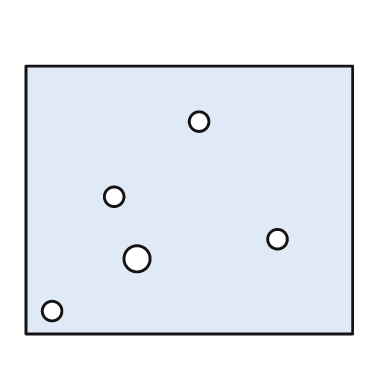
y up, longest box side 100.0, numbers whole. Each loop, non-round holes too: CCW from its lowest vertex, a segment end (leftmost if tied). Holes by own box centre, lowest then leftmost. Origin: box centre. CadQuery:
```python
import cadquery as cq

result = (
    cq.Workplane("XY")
    .moveTo(-50.0, -41.0)
    .lineTo(50.0, -41.0)
    .lineTo(50.0, 41.0)
    .lineTo(-50.0, 41.0)
    .close()
    .moveTo(-42.0, -34.0)
    .circle(3.0)
    .moveTo(-16.0, -18.0)
    .circle(4.0)
    .moveTo(27.0, -12.0)
    .circle(3.0)
    .moveTo(-23.0, 1.0)
    .circle(3.0)
    .moveTo(3.0, 24.0)
    .circle(3.0)
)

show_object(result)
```